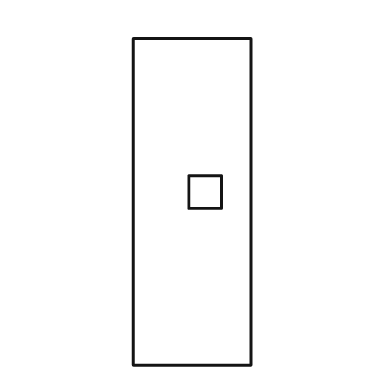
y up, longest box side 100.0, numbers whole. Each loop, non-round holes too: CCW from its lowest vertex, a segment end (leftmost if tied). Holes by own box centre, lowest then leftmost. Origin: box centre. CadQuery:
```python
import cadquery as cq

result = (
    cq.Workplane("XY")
    .moveTo(-18.0, -50.0)
    .lineTo(18.0, -50.0)
    .lineTo(18.0, 50.0)
    .lineTo(-18.0, 50.0)
    .close()
    .moveTo(-1.0, -2.0)
    .lineTo(9.0, -2.0)
    .lineTo(9.0, 8.0)
    .lineTo(-1.0, 8.0)
    .close()
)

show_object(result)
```